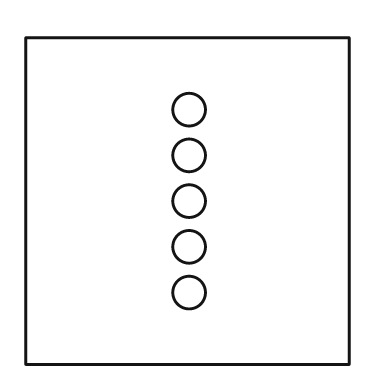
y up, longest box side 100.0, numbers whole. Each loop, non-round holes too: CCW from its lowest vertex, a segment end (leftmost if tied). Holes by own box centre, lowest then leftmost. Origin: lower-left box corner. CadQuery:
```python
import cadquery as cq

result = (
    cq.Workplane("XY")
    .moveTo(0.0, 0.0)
    .lineTo(99.0, 0.0)
    .lineTo(99.0, 100.0)
    .lineTo(0.0, 100.0)
    .close()
    .moveTo(50.0, 22.0)
    .circle(5.0)
    .moveTo(50.0, 36.0)
    .circle(5.0)
    .moveTo(50.0, 50.0)
    .circle(5.0)
    .moveTo(50.0, 64.0)
    .circle(5.0)
    .moveTo(50.0, 78.0)
    .circle(5.0)
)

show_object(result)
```